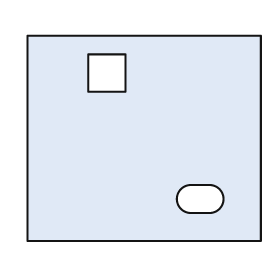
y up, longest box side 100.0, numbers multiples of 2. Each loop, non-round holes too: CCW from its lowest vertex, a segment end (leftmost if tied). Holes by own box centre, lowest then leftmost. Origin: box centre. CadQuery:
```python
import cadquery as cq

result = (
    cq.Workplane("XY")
    .moveTo(-50.0, -44.0)
    .lineTo(50.0, -44.0)
    .lineTo(50.0, 44.0)
    .lineTo(-50.0, 44.0)
    .close()
    .moveTo(20.0, -32.0)
    .lineTo(28.0, -32.0)
    .threePointArc((34.0, -26.0), (28.0, -20.0))
    .lineTo(20.0, -20.0)
    .threePointArc((14.0, -26.0), (20.0, -32.0))
    .close()
    .moveTo(-24.0, 20.0)
    .lineTo(-8.0, 20.0)
    .lineTo(-8.0, 36.0)
    .lineTo(-24.0, 36.0)
    .close()
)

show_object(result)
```